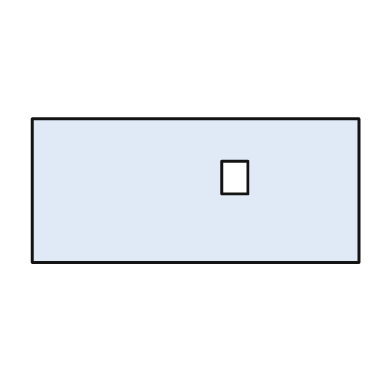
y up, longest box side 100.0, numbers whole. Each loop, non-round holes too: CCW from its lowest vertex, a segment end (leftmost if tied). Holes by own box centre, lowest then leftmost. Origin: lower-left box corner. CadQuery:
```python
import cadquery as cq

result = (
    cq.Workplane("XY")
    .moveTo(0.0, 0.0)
    .lineTo(100.0, 0.0)
    .lineTo(100.0, 44.0)
    .lineTo(0.0, 44.0)
    .close()
    .moveTo(58.0, 21.0)
    .lineTo(66.0, 21.0)
    .lineTo(66.0, 31.0)
    .lineTo(58.0, 31.0)
    .close()
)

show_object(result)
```